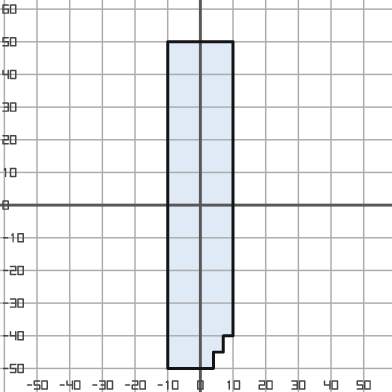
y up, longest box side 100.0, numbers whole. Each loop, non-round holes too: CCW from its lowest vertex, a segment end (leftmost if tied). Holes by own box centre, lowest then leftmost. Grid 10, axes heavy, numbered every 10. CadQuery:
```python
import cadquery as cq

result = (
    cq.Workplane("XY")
    .moveTo(-10.0, -50.0)
    .lineTo(4.0, -50.0)
    .lineTo(4.0, -45.0)
    .lineTo(7.0, -45.0)
    .lineTo(7.0, -40.0)
    .lineTo(10.0, -40.0)
    .lineTo(10.0, 50.0)
    .lineTo(-10.0, 50.0)
    .close()
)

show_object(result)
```